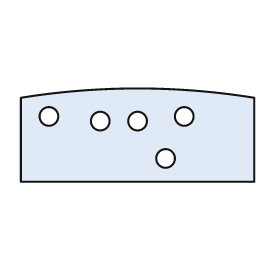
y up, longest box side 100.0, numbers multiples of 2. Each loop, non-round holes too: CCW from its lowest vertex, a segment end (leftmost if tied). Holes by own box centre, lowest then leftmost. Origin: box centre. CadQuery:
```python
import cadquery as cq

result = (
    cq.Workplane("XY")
    .moveTo(-50.0, -20.0)
    .lineTo(50.0, -20.0)
    .lineTo(50.0, 16.0)
    .threePointArc((0.0, 20.0), (-50.0, 16.0))
    .close()
    .moveTo(12.0, -10.0)
    .circle(4.0)
    .moveTo(-16.0, 6.0)
    .circle(4.0)
    .moveTo(0.0, 6.0)
    .circle(4.0)
    .moveTo(-38.0, 8.0)
    .circle(4.0)
    .moveTo(20.0, 8.0)
    .circle(4.0)
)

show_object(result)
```